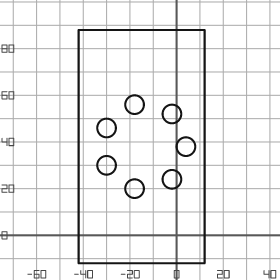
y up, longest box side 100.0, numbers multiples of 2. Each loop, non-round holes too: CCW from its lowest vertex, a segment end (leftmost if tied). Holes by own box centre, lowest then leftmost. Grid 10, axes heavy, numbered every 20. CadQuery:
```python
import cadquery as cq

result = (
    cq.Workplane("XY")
    .moveTo(-42.0, -12.0)
    .lineTo(12.0, -12.0)
    .lineTo(12.0, 88.0)
    .lineTo(-42.0, 88.0)
    .close()
    .moveTo(-18.0, 20.0)
    .circle(4.0)
    .moveTo(-2.0, 24.0)
    .circle(4.0)
    .moveTo(-30.0, 30.0)
    .circle(4.0)
    .moveTo(4.0, 38.0)
    .circle(4.0)
    .moveTo(-30.0, 46.0)
    .circle(4.0)
    .moveTo(-2.0, 52.0)
    .circle(4.0)
    .moveTo(-18.0, 56.0)
    .circle(4.0)
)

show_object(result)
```